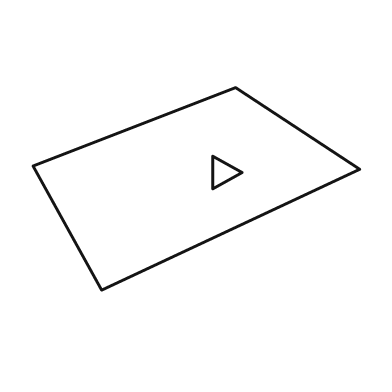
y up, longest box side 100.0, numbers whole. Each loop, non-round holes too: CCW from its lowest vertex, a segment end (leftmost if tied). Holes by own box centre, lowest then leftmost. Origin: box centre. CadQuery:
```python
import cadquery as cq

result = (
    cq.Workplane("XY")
    .moveTo(-29.0, -31.0)
    .lineTo(50.0, 6.0)
    .lineTo(12.0, 31.0)
    .lineTo(-50.0, 7.0)
    .close()
    .moveTo(5.0, 0.0)
    .lineTo(14.0, 5.0)
    .lineTo(5.0, 10.0)
    .close()
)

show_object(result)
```